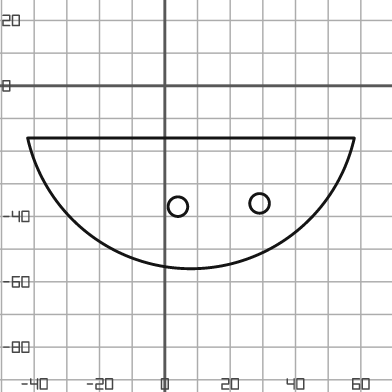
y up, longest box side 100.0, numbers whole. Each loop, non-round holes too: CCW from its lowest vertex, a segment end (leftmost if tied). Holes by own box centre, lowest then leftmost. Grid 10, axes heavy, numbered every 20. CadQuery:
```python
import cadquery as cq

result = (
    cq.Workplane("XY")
    .moveTo(-42.0, -16.0)
    .threePointArc((8.0, -56.0), (58.0, -16.0))
    .close()
    .moveTo(4.0, -37.0)
    .circle(3.0)
    .moveTo(29.0, -36.0)
    .circle(3.0)
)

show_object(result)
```